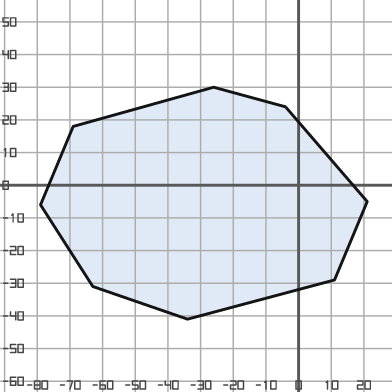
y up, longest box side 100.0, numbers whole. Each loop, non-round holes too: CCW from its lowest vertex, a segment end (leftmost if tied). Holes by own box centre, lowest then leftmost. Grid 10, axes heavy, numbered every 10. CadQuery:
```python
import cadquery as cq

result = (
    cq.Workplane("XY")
    .moveTo(-34.0, -41.0)
    .lineTo(11.0, -29.0)
    .lineTo(21.0, -5.0)
    .lineTo(-4.0, 24.0)
    .lineTo(-26.0, 30.0)
    .lineTo(-69.0, 18.0)
    .lineTo(-79.0, -6.0)
    .lineTo(-63.0, -31.0)
    .close()
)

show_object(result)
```